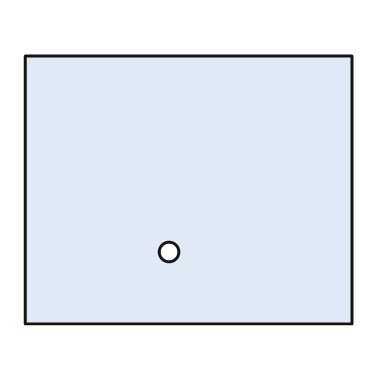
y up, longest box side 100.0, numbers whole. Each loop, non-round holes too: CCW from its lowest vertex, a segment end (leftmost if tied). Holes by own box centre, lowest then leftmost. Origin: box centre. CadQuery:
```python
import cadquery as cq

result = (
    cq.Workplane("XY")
    .moveTo(-50.0, -41.0)
    .lineTo(50.0, -41.0)
    .lineTo(50.0, 41.0)
    .lineTo(-50.0, 41.0)
    .close()
    .moveTo(-6.0, -19.0)
    .circle(3.0)
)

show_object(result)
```